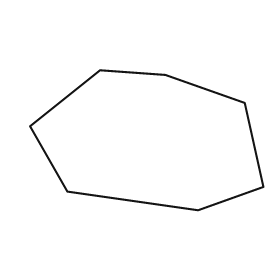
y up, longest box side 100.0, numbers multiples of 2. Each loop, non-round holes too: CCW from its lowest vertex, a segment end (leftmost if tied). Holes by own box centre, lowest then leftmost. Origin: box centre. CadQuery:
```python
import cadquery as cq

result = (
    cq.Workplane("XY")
    .moveTo(22.0, -30.0)
    .lineTo(50.0, -20.0)
    .lineTo(42.0, 16.0)
    .lineTo(8.0, 28.0)
    .lineTo(-20.0, 30.0)
    .lineTo(-50.0, 6.0)
    .lineTo(-34.0, -22.0)
    .close()
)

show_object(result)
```